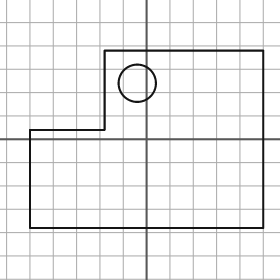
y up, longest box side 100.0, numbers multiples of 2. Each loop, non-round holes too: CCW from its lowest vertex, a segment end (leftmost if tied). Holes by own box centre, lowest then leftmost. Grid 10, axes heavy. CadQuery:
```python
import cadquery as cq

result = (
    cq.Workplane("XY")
    .moveTo(-50.0, -38.0)
    .lineTo(50.0, -38.0)
    .lineTo(50.0, 38.0)
    .lineTo(-18.0, 38.0)
    .lineTo(-18.0, 4.0)
    .lineTo(-50.0, 4.0)
    .close()
    .moveTo(-4.0, 24.0)
    .circle(8.0)
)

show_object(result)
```